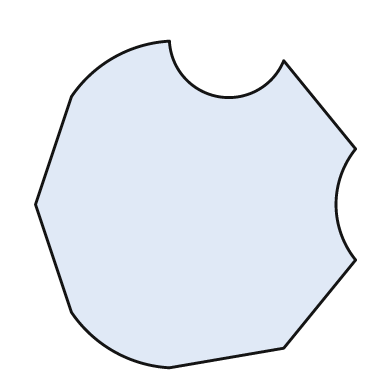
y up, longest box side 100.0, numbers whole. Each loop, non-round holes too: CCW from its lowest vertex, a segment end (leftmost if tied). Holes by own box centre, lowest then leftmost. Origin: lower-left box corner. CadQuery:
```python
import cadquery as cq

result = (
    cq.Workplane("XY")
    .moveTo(41.0, 0.0)
    .lineTo(76.0, 6.0)
    .lineTo(98.0, 33.0)
    .threePointArc((92.0, 50.0), (98.0, 67.0))
    .lineTo(76.0, 94.0)
    .threePointArc((56.0, 83.0), (41.0, 100.0))
    .threePointArc((24.0, 95.0), (11.0, 83.0))
    .lineTo(0.0, 50.0)
    .lineTo(11.0, 17.0)
    .threePointArc((24.0, 5.0), (41.0, 0.0))
    .close()
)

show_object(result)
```